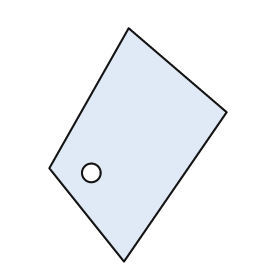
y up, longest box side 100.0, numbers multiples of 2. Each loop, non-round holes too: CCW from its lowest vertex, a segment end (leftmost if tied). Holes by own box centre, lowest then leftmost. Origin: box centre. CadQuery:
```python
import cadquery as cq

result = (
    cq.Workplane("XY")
    .moveTo(-6.0, -50.0)
    .lineTo(38.0, 14.0)
    .lineTo(-4.0, 50.0)
    .lineTo(-38.0, -10.0)
    .close()
    .moveTo(-20.0, -12.0)
    .circle(4.0)
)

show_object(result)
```